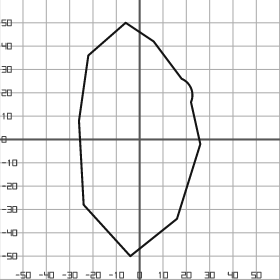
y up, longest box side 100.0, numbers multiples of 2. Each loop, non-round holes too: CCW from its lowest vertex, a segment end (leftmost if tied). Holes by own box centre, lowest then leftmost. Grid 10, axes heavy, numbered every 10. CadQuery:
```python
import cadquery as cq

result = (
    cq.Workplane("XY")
    .moveTo(-4.0, -50.0)
    .lineTo(16.0, -34.0)
    .lineTo(26.0, -2.0)
    .lineTo(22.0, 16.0)
    .threePointArc((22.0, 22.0), (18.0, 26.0))
    .lineTo(6.0, 42.0)
    .lineTo(-6.0, 50.0)
    .lineTo(-22.0, 36.0)
    .lineTo(-26.0, 8.0)
    .lineTo(-24.0, -28.0)
    .close()
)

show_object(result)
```